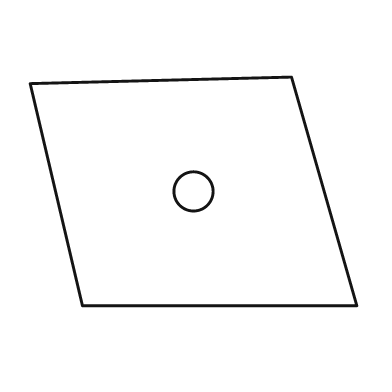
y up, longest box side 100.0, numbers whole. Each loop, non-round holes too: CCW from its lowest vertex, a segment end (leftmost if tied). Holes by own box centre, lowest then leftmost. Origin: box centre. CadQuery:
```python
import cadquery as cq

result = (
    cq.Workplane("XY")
    .moveTo(-34.0, -35.0)
    .lineTo(50.0, -35.0)
    .lineTo(30.0, 35.0)
    .lineTo(-50.0, 33.0)
    .close()
    .moveTo(0.0, 0.0)
    .circle(6.0)
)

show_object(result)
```